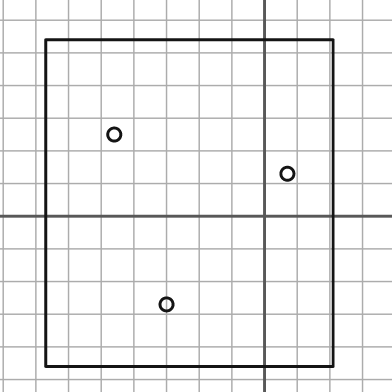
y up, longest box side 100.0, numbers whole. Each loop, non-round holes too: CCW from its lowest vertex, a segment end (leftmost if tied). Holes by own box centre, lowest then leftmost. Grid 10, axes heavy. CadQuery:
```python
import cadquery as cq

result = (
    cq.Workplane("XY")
    .moveTo(-67.0, -46.0)
    .lineTo(21.0, -46.0)
    .lineTo(21.0, 54.0)
    .lineTo(-67.0, 54.0)
    .close()
    .moveTo(-30.0, -27.0)
    .circle(2.0)
    .moveTo(7.0, 13.0)
    .circle(2.0)
    .moveTo(-46.0, 25.0)
    .circle(2.0)
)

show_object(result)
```